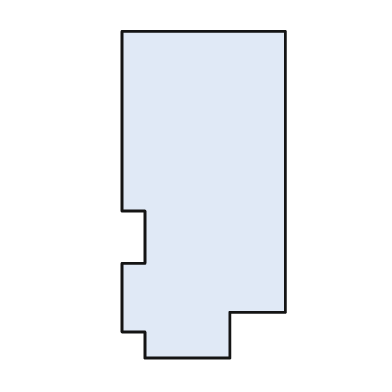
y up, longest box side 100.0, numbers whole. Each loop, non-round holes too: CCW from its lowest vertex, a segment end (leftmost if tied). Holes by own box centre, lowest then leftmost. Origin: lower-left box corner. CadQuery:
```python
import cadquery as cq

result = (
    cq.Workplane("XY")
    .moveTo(7.0, 0.0)
    .lineTo(33.0, 0.0)
    .lineTo(33.0, 14.0)
    .lineTo(50.0, 14.0)
    .lineTo(50.0, 100.0)
    .lineTo(0.0, 100.0)
    .lineTo(0.0, 45.0)
    .lineTo(7.0, 45.0)
    .lineTo(7.0, 29.0)
    .lineTo(0.0, 29.0)
    .lineTo(0.0, 8.0)
    .lineTo(7.0, 8.0)
    .close()
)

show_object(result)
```